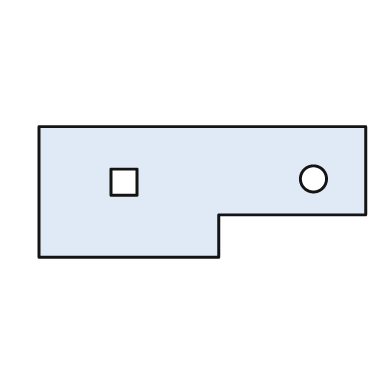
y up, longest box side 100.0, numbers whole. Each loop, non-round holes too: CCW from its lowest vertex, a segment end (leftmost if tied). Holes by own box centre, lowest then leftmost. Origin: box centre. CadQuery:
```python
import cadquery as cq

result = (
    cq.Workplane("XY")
    .moveTo(-50.0, -20.0)
    .lineTo(5.0, -20.0)
    .lineTo(5.0, -7.0)
    .lineTo(50.0, -7.0)
    .lineTo(50.0, 20.0)
    .lineTo(-50.0, 20.0)
    .close()
    .moveTo(-28.0, -1.0)
    .lineTo(-20.0, -1.0)
    .lineTo(-20.0, 7.0)
    .lineTo(-28.0, 7.0)
    .close()
    .moveTo(34.0, 4.0)
    .circle(4.0)
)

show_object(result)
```